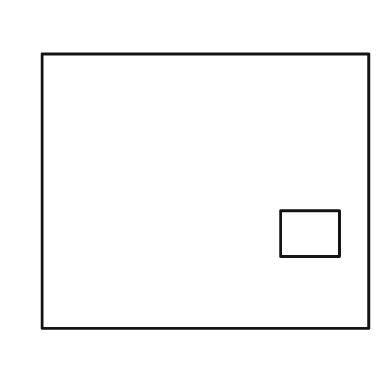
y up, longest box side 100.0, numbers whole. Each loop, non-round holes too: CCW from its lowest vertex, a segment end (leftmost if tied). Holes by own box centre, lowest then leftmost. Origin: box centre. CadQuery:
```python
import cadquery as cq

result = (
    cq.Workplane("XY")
    .moveTo(-50.0, -42.0)
    .lineTo(50.0, -42.0)
    .lineTo(50.0, 42.0)
    .lineTo(-50.0, 42.0)
    .close()
    .moveTo(23.0, -20.0)
    .lineTo(41.0, -20.0)
    .lineTo(41.0, -6.0)
    .lineTo(23.0, -6.0)
    .close()
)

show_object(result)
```